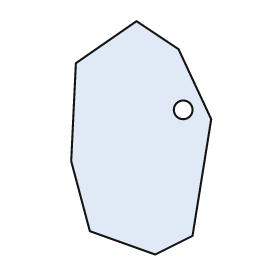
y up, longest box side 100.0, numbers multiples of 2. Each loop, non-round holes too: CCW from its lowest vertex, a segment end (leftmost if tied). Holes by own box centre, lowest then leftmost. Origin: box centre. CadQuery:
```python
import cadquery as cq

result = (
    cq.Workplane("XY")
    .moveTo(6.0, -50.0)
    .lineTo(22.0, -42.0)
    .lineTo(30.0, 8.0)
    .lineTo(16.0, 38.0)
    .lineTo(-2.0, 50.0)
    .lineTo(-28.0, 32.0)
    .lineTo(-30.0, -10.0)
    .lineTo(-22.0, -40.0)
    .close()
    .moveTo(18.0, 12.0)
    .circle(4.0)
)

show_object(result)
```